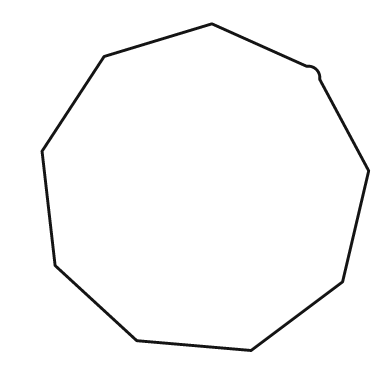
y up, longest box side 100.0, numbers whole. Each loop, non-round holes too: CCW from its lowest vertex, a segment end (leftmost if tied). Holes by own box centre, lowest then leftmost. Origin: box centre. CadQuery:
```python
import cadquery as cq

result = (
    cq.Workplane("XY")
    .moveTo(14.0, -50.0)
    .lineTo(42.0, -29.0)
    .lineTo(50.0, 5.0)
    .lineTo(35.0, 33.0)
    .threePointArc((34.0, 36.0), (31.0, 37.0))
    .lineTo(2.0, 50.0)
    .lineTo(-31.0, 40.0)
    .lineTo(-50.0, 11.0)
    .lineTo(-46.0, -24.0)
    .lineTo(-21.0, -47.0)
    .close()
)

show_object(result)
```